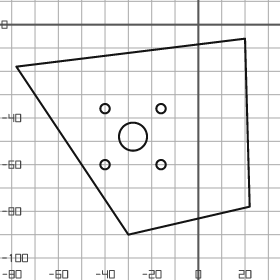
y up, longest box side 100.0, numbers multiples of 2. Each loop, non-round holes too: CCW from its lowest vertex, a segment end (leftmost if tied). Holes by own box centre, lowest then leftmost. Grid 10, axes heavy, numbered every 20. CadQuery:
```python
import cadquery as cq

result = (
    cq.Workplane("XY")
    .moveTo(-30.0, -90.0)
    .lineTo(22.0, -78.0)
    .lineTo(20.0, -6.0)
    .lineTo(-78.0, -18.0)
    .close()
    .moveTo(-40.0, -60.0)
    .circle(2.0)
    .moveTo(-16.0, -60.0)
    .circle(2.0)
    .moveTo(-28.0, -48.0)
    .circle(6.0)
    .moveTo(-40.0, -36.0)
    .circle(2.0)
    .moveTo(-16.0, -36.0)
    .circle(2.0)
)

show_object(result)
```